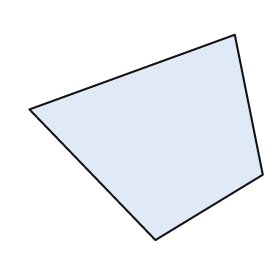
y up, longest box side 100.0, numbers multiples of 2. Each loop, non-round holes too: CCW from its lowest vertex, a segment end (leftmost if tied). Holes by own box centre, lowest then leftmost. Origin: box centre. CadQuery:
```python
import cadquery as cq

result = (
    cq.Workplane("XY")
    .moveTo(4.0, -44.0)
    .lineTo(50.0, -16.0)
    .lineTo(38.0, 44.0)
    .lineTo(-50.0, 12.0)
    .close()
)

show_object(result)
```